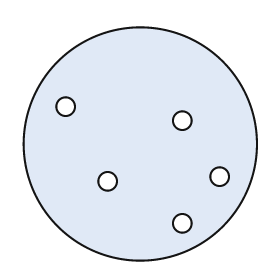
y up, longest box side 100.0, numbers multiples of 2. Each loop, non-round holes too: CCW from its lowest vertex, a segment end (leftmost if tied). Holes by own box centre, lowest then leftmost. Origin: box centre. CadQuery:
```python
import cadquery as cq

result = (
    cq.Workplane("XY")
    .moveTo(0.0, 0.0)
    .circle(50.0)
    .moveTo(18.0, -34.0)
    .circle(4.0)
    .moveTo(-14.0, -16.0)
    .circle(4.0)
    .moveTo(34.0, -14.0)
    .circle(4.0)
    .moveTo(18.0, 10.0)
    .circle(4.0)
    .moveTo(-32.0, 16.0)
    .circle(4.0)
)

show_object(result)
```